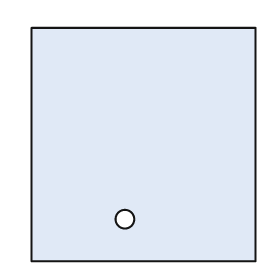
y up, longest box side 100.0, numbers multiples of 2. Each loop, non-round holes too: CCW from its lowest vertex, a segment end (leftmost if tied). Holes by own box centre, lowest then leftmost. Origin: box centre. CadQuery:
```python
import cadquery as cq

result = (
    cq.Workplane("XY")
    .moveTo(-48.0, -50.0)
    .lineTo(48.0, -50.0)
    .lineTo(48.0, 50.0)
    .lineTo(-48.0, 50.0)
    .close()
    .moveTo(-8.0, -32.0)
    .circle(4.0)
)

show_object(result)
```